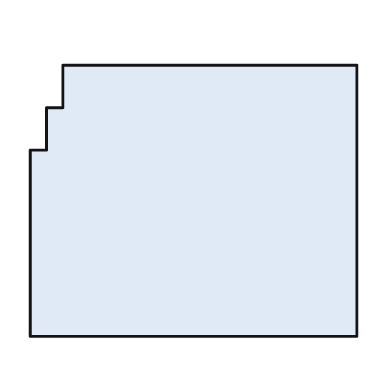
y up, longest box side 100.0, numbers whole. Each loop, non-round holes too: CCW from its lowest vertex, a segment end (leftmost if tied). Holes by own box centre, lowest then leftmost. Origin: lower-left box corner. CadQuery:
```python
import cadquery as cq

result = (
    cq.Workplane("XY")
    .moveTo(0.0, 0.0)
    .lineTo(100.0, 0.0)
    .lineTo(100.0, 83.0)
    .lineTo(10.0, 83.0)
    .lineTo(10.0, 70.0)
    .lineTo(5.0, 70.0)
    .lineTo(5.0, 57.0)
    .lineTo(0.0, 57.0)
    .close()
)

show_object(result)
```